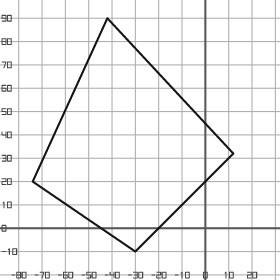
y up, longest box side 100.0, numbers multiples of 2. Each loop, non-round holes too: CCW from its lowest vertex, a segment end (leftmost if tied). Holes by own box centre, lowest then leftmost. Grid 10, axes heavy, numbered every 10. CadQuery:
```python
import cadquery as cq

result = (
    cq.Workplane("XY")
    .moveTo(-30.0, -10.0)
    .lineTo(12.0, 32.0)
    .lineTo(-42.0, 90.0)
    .lineTo(-74.0, 20.0)
    .close()
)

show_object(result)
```